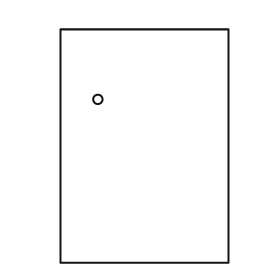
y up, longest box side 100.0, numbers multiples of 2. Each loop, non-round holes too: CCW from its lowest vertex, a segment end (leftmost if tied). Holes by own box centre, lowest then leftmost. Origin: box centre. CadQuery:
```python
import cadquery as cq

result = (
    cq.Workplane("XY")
    .moveTo(-36.0, -50.0)
    .lineTo(36.0, -50.0)
    .lineTo(36.0, 50.0)
    .lineTo(-36.0, 50.0)
    .close()
    .moveTo(-20.0, 20.0)
    .circle(2.0)
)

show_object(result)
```